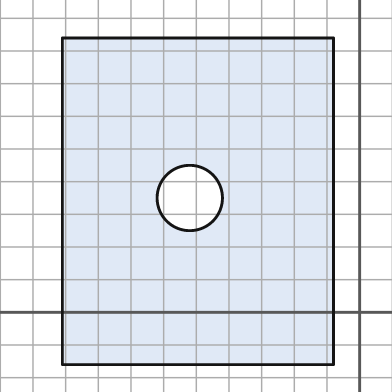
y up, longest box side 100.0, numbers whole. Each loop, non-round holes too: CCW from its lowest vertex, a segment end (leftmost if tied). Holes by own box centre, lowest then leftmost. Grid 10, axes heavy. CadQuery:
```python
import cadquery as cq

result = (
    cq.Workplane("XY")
    .moveTo(-91.0, -16.0)
    .lineTo(-8.0, -16.0)
    .lineTo(-8.0, 84.0)
    .lineTo(-91.0, 84.0)
    .close()
    .moveTo(-52.0, 35.0)
    .circle(10.0)
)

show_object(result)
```